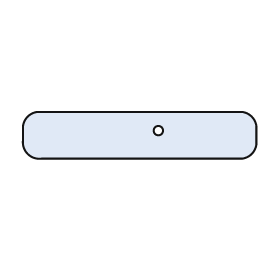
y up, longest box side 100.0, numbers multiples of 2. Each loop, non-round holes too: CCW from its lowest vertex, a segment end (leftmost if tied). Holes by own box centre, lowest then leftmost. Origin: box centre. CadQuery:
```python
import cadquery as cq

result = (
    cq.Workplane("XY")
    .moveTo(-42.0, -10.0)
    .lineTo(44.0, -10.0)
    .threePointArc((48.0, -8.0), (50.0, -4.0))
    .lineTo(50.0, 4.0)
    .threePointArc((48.0, 8.0), (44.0, 10.0))
    .lineTo(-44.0, 10.0)
    .threePointArc((-48.0, 8.0), (-50.0, 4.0))
    .lineTo(-50.0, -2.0)
    .threePointArc((-48.0, -8.0), (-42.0, -10.0))
    .close()
    .moveTo(8.0, 2.0)
    .circle(2.0)
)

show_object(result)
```